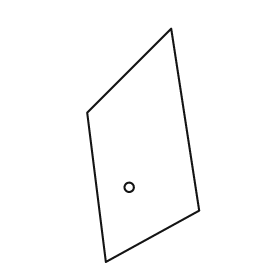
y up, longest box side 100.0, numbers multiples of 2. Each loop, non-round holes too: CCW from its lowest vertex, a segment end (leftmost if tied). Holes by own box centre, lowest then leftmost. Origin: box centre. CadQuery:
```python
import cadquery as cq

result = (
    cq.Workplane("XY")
    .moveTo(-16.0, -50.0)
    .lineTo(24.0, -28.0)
    .lineTo(12.0, 50.0)
    .lineTo(-24.0, 14.0)
    .close()
    .moveTo(-6.0, -18.0)
    .circle(2.0)
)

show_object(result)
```